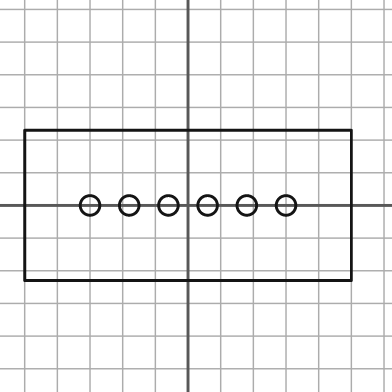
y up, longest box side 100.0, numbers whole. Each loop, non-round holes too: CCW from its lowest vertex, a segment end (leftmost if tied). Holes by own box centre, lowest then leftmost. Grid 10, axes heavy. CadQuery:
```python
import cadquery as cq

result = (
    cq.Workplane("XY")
    .moveTo(-50.0, -23.0)
    .lineTo(50.0, -23.0)
    .lineTo(50.0, 23.0)
    .lineTo(-50.0, 23.0)
    .close()
    .moveTo(-30.0, 0.0)
    .circle(3.0)
    .moveTo(-18.0, 0.0)
    .circle(3.0)
    .moveTo(-6.0, 0.0)
    .circle(3.0)
    .moveTo(6.0, 0.0)
    .circle(3.0)
    .moveTo(18.0, 0.0)
    .circle(3.0)
    .moveTo(30.0, 0.0)
    .circle(3.0)
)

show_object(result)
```